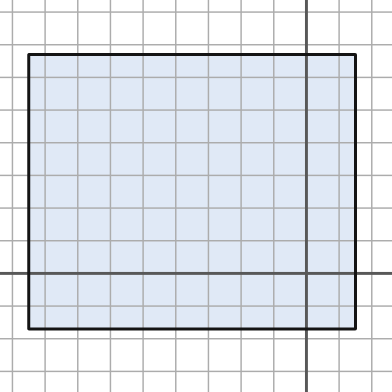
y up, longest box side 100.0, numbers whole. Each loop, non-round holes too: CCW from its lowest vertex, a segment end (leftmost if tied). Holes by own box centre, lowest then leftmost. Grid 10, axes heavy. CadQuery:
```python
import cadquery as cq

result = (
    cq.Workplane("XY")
    .moveTo(-85.0, -17.0)
    .lineTo(15.0, -17.0)
    .lineTo(15.0, 67.0)
    .lineTo(-85.0, 67.0)
    .close()
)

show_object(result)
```